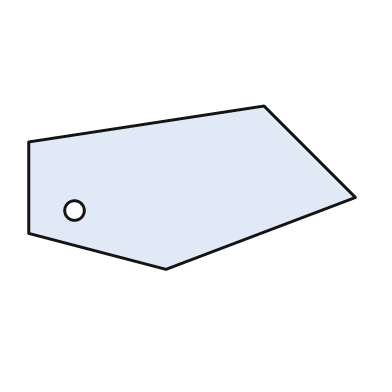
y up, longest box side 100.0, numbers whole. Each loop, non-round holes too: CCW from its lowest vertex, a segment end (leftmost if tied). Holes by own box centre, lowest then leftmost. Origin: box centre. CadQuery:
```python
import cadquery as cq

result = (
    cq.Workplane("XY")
    .moveTo(-8.0, -25.0)
    .lineTo(50.0, -3.0)
    .lineTo(22.0, 25.0)
    .lineTo(-50.0, 14.0)
    .lineTo(-50.0, -14.0)
    .close()
    .moveTo(-36.0, -7.0)
    .circle(3.0)
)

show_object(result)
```